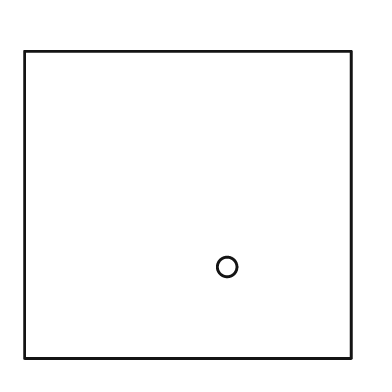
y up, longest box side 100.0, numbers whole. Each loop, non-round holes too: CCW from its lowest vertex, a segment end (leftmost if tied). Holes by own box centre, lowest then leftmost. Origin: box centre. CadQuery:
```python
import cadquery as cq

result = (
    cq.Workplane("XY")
    .moveTo(-50.0, -47.0)
    .lineTo(50.0, -47.0)
    .lineTo(50.0, 47.0)
    .lineTo(-50.0, 47.0)
    .close()
    .moveTo(12.0, -19.0)
    .circle(3.0)
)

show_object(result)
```